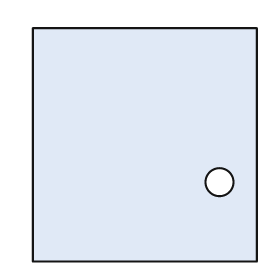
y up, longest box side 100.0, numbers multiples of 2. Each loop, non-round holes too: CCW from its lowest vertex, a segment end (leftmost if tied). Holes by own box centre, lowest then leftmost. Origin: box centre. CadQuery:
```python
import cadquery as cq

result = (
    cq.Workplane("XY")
    .moveTo(-48.0, -50.0)
    .lineTo(48.0, -50.0)
    .lineTo(48.0, 50.0)
    .lineTo(-48.0, 50.0)
    .close()
    .moveTo(32.0, -16.0)
    .circle(6.0)
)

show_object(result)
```